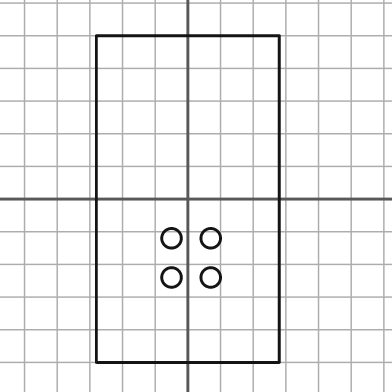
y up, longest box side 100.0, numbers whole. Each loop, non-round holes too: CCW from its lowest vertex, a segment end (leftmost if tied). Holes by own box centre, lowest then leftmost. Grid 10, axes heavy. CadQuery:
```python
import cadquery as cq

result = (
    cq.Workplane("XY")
    .moveTo(-28.0, -50.0)
    .lineTo(28.0, -50.0)
    .lineTo(28.0, 50.0)
    .lineTo(-28.0, 50.0)
    .close()
    .moveTo(-5.0, -24.0)
    .circle(3.0)
    .moveTo(7.0, -24.0)
    .circle(3.0)
    .moveTo(-5.0, -12.0)
    .circle(3.0)
    .moveTo(7.0, -12.0)
    .circle(3.0)
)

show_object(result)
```